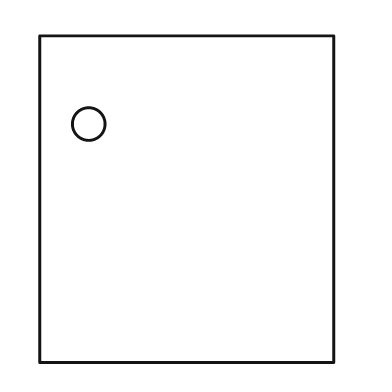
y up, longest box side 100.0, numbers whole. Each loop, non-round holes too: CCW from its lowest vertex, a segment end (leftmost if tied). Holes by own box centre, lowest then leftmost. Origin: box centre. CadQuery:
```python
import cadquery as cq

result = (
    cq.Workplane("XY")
    .moveTo(-45.0, -50.0)
    .lineTo(45.0, -50.0)
    .lineTo(45.0, 50.0)
    .lineTo(-45.0, 50.0)
    .close()
    .moveTo(-30.0, 23.0)
    .circle(5.0)
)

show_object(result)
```